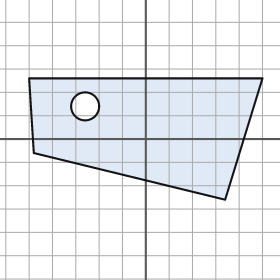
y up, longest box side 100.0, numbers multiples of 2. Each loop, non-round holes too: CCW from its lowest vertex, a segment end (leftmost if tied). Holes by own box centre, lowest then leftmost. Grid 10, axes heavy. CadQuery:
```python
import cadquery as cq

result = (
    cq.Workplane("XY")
    .moveTo(34.0, -26.0)
    .lineTo(50.0, 26.0)
    .lineTo(-50.0, 26.0)
    .lineTo(-48.0, -6.0)
    .close()
    .moveTo(-26.0, 14.0)
    .circle(6.0)
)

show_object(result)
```